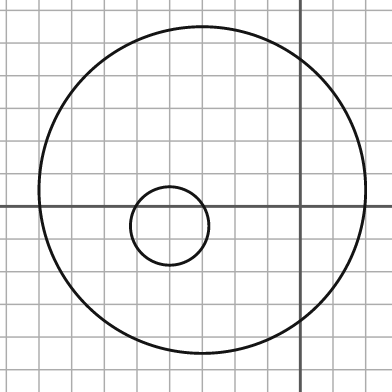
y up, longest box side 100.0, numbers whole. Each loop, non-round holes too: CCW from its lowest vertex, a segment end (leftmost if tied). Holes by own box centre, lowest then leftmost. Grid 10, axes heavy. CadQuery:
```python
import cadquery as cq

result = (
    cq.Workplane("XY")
    .moveTo(-30.0, 5.0)
    .circle(50.0)
    .moveTo(-40.0, -6.0)
    .circle(12.0)
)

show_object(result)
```